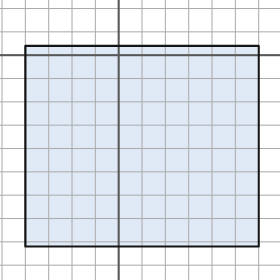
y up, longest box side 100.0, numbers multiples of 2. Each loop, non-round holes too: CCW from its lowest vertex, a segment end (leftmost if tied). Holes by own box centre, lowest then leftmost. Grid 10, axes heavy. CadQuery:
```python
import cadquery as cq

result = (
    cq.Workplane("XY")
    .moveTo(-40.0, -82.0)
    .lineTo(60.0, -82.0)
    .lineTo(60.0, 4.0)
    .lineTo(-40.0, 4.0)
    .close()
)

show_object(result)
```